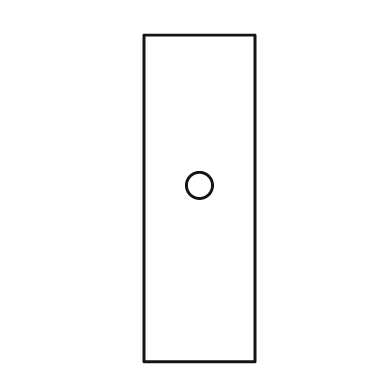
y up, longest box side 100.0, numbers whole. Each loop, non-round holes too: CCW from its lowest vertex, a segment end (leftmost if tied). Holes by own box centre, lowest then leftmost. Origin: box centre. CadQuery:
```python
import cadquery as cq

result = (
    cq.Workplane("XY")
    .moveTo(-17.0, -50.0)
    .lineTo(17.0, -50.0)
    .lineTo(17.0, 50.0)
    .lineTo(-17.0, 50.0)
    .close()
    .moveTo(0.0, 4.0)
    .circle(4.0)
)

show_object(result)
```